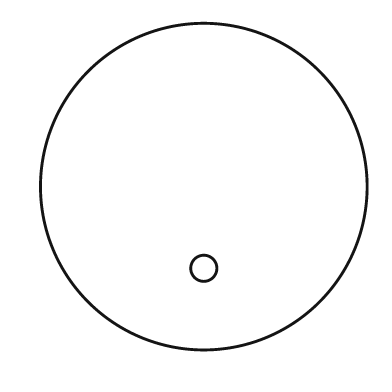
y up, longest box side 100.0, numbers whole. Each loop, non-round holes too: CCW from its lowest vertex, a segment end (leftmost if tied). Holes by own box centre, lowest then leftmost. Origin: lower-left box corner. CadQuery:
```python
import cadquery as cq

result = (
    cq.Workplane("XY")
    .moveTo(50.0, 50.0)
    .circle(50.0)
    .moveTo(50.0, 25.0)
    .circle(4.0)
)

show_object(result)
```